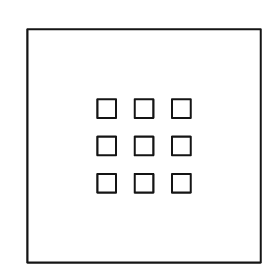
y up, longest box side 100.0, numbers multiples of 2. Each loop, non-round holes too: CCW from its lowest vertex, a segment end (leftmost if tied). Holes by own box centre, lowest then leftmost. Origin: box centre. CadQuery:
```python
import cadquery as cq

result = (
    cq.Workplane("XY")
    .moveTo(-50.0, -50.0)
    .lineTo(50.0, -50.0)
    .lineTo(50.0, 50.0)
    .lineTo(-50.0, 50.0)
    .close()
    .moveTo(-20.0, -20.0)
    .lineTo(-12.0, -20.0)
    .lineTo(-12.0, -12.0)
    .lineTo(-20.0, -12.0)
    .close()
    .moveTo(-4.0, -20.0)
    .lineTo(4.0, -20.0)
    .lineTo(4.0, -12.0)
    .lineTo(-4.0, -12.0)
    .close()
    .moveTo(12.0, -20.0)
    .lineTo(20.0, -20.0)
    .lineTo(20.0, -12.0)
    .lineTo(12.0, -12.0)
    .close()
    .moveTo(-20.0, -4.0)
    .lineTo(-12.0, -4.0)
    .lineTo(-12.0, 4.0)
    .lineTo(-20.0, 4.0)
    .close()
    .moveTo(-4.0, -4.0)
    .lineTo(4.0, -4.0)
    .lineTo(4.0, 4.0)
    .lineTo(-4.0, 4.0)
    .close()
    .moveTo(12.0, -4.0)
    .lineTo(20.0, -4.0)
    .lineTo(20.0, 4.0)
    .lineTo(12.0, 4.0)
    .close()
    .moveTo(-20.0, 12.0)
    .lineTo(-12.0, 12.0)
    .lineTo(-12.0, 20.0)
    .lineTo(-20.0, 20.0)
    .close()
    .moveTo(-4.0, 12.0)
    .lineTo(4.0, 12.0)
    .lineTo(4.0, 20.0)
    .lineTo(-4.0, 20.0)
    .close()
    .moveTo(12.0, 12.0)
    .lineTo(20.0, 12.0)
    .lineTo(20.0, 20.0)
    .lineTo(12.0, 20.0)
    .close()
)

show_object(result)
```